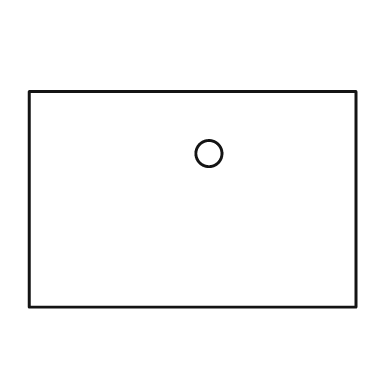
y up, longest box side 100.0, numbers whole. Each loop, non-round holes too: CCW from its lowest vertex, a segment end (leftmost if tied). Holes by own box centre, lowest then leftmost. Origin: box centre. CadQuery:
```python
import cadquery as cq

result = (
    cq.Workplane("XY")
    .moveTo(-50.0, -33.0)
    .lineTo(50.0, -33.0)
    .lineTo(50.0, 33.0)
    .lineTo(-50.0, 33.0)
    .close()
    .moveTo(5.0, 14.0)
    .circle(4.0)
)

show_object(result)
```